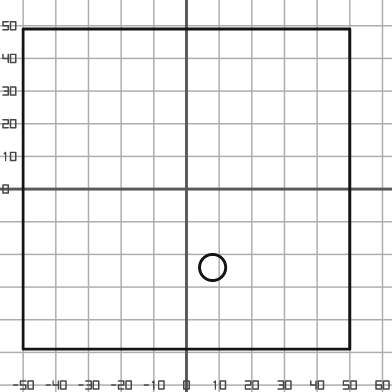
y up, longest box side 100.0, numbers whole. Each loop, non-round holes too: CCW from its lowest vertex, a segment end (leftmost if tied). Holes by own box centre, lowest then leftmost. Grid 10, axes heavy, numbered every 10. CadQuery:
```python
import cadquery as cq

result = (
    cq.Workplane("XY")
    .moveTo(-50.0, -49.0)
    .lineTo(50.0, -49.0)
    .lineTo(50.0, 49.0)
    .lineTo(-50.0, 49.0)
    .close()
    .moveTo(8.0, -24.0)
    .circle(4.0)
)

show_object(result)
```